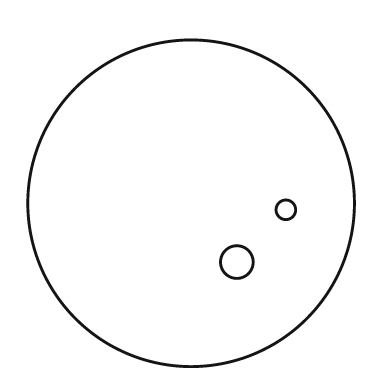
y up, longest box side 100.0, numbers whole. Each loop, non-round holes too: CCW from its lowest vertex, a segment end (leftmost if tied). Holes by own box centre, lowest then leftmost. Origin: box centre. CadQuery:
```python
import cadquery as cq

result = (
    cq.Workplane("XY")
    .moveTo(0.0, 0.0)
    .circle(50.0)
    .moveTo(14.0, -18.0)
    .circle(5.0)
    .moveTo(29.0, -2.0)
    .circle(3.0)
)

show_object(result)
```